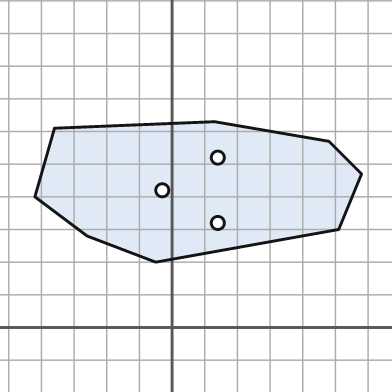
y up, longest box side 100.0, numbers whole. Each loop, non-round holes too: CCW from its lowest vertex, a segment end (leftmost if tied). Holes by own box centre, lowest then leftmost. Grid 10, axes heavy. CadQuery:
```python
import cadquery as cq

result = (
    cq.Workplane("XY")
    .moveTo(-5.0, 20.0)
    .lineTo(51.0, 30.0)
    .lineTo(58.0, 47.0)
    .lineTo(48.0, 57.0)
    .lineTo(13.0, 63.0)
    .lineTo(-36.0, 61.0)
    .lineTo(-42.0, 40.0)
    .lineTo(-26.0, 28.0)
    .close()
    .moveTo(14.0, 32.0)
    .circle(2.0)
    .moveTo(-3.0, 42.0)
    .circle(2.0)
    .moveTo(14.0, 52.0)
    .circle(2.0)
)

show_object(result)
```